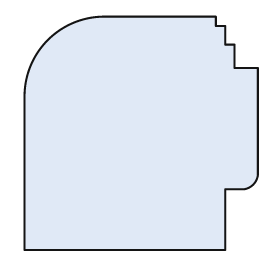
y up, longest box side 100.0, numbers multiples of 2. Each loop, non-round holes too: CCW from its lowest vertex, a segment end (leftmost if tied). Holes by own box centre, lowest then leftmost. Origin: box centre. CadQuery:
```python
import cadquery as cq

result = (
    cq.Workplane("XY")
    .moveTo(-50.0, -50.0)
    .lineTo(36.0, -50.0)
    .lineTo(36.0, -24.0)
    .lineTo(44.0, -24.0)
    .threePointArc((48.0, -22.0), (50.0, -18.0))
    .lineTo(50.0, 28.0)
    .lineTo(40.0, 28.0)
    .lineTo(40.0, 38.0)
    .lineTo(36.0, 38.0)
    .lineTo(36.0, 46.0)
    .lineTo(32.0, 46.0)
    .lineTo(32.0, 50.0)
    .lineTo(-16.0, 50.0)
    .threePointArc((-40.0, 40.0), (-50.0, 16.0))
    .close()
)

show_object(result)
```